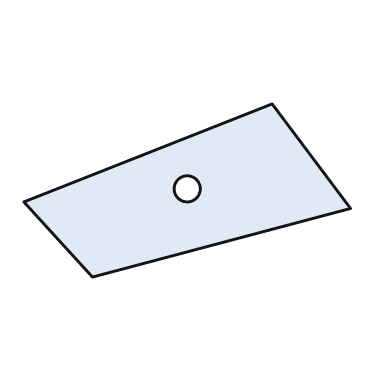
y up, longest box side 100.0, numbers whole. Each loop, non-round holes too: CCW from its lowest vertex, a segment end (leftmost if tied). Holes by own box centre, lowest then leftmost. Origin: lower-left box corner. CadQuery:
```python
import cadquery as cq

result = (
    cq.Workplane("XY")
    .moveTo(21.0, 0.0)
    .lineTo(100.0, 21.0)
    .lineTo(76.0, 53.0)
    .lineTo(0.0, 23.0)
    .close()
    .moveTo(50.0, 27.0)
    .circle(4.0)
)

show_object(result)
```